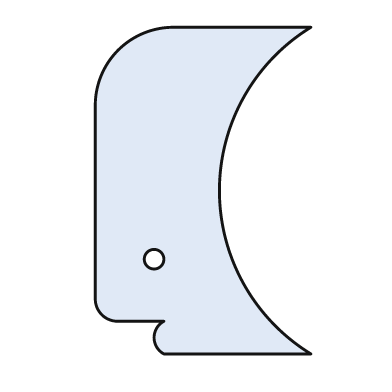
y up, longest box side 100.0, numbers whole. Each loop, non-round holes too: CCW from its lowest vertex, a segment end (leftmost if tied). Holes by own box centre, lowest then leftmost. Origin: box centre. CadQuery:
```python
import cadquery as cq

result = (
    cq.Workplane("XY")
    .moveTo(-12.0, -50.0)
    .lineTo(33.0, -50.0)
    .threePointArc((5.0, 0.0), (33.0, 50.0))
    .lineTo(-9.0, 50.0)
    .threePointArc((-26.0, 43.0), (-33.0, 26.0))
    .lineTo(-33.0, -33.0)
    .threePointArc((-31.0, -38.0), (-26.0, -40.0))
    .lineTo(-12.0, -40.0)
    .threePointArc((-15.0, -45.0), (-12.0, -50.0))
    .close()
    .moveTo(-15.0, -21.0)
    .circle(3.0)
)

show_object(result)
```